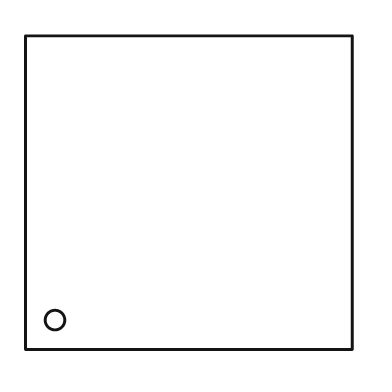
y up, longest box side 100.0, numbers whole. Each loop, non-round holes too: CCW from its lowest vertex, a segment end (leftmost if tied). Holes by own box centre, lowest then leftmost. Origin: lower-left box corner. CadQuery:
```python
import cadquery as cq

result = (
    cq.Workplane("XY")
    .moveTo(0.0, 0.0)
    .lineTo(100.0, 0.0)
    .lineTo(100.0, 96.0)
    .lineTo(0.0, 96.0)
    .close()
    .moveTo(9.0, 9.0)
    .circle(3.0)
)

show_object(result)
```